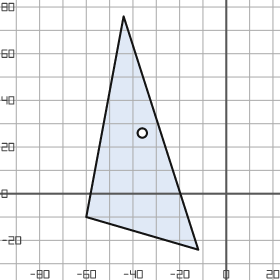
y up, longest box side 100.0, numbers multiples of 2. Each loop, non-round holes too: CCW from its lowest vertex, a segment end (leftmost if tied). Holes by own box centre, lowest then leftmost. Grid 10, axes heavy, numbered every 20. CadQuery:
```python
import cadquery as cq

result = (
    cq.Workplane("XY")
    .moveTo(-12.0, -24.0)
    .lineTo(-44.0, 76.0)
    .lineTo(-60.0, -10.0)
    .close()
    .moveTo(-36.0, 26.0)
    .circle(2.0)
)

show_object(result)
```